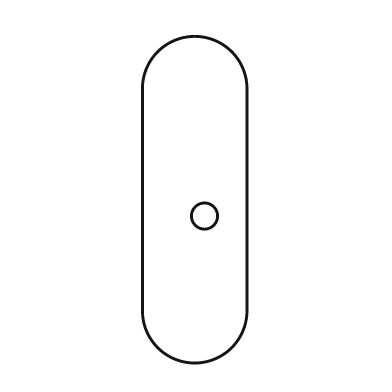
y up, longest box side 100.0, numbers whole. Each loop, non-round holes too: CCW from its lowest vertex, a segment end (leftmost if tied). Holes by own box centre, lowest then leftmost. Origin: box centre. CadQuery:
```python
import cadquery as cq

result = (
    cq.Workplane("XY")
    .moveTo(-16.0, -34.0)
    .threePointArc((0.0, -50.0), (16.0, -34.0))
    .lineTo(16.0, 34.0)
    .threePointArc((0.0, 50.0), (-16.0, 34.0))
    .close()
    .moveTo(3.0, -5.0)
    .circle(4.0)
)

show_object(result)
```